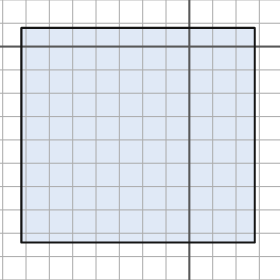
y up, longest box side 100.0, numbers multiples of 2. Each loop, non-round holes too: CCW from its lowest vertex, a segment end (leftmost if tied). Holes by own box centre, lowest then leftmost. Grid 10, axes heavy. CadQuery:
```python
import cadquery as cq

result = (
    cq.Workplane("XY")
    .moveTo(-72.0, -84.0)
    .lineTo(28.0, -84.0)
    .lineTo(28.0, 8.0)
    .lineTo(-72.0, 8.0)
    .close()
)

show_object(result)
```